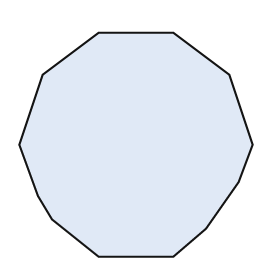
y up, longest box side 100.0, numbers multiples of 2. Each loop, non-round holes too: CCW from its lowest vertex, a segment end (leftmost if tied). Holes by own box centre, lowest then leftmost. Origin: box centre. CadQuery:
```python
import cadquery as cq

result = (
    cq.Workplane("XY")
    .moveTo(-16.0, -48.0)
    .lineTo(16.0, -48.0)
    .lineTo(30.0, -36.0)
    .lineTo(44.0, -16.0)
    .lineTo(50.0, 0.0)
    .lineTo(40.0, 30.0)
    .lineTo(16.0, 48.0)
    .lineTo(-16.0, 48.0)
    .lineTo(-40.0, 30.0)
    .lineTo(-50.0, 0.0)
    .lineTo(-42.0, -22.0)
    .lineTo(-36.0, -32.0)
    .close()
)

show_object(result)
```